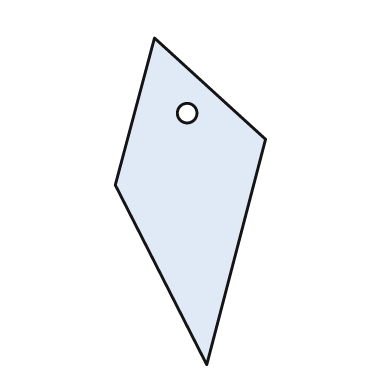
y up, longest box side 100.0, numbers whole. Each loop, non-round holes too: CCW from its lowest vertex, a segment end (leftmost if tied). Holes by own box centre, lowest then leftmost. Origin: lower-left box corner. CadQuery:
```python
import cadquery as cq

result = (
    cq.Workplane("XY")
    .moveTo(28.0, 0.0)
    .lineTo(46.0, 69.0)
    .lineTo(12.0, 100.0)
    .lineTo(0.0, 55.0)
    .close()
    .moveTo(22.0, 77.0)
    .circle(3.0)
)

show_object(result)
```